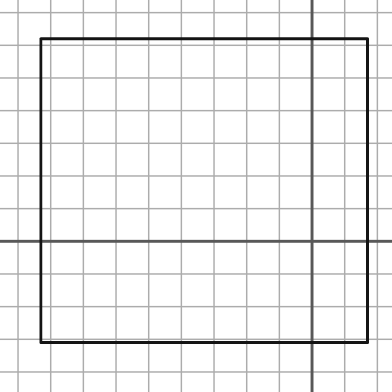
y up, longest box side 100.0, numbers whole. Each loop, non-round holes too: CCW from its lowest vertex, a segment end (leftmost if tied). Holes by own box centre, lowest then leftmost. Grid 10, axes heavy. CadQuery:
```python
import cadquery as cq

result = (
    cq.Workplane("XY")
    .moveTo(-83.0, -31.0)
    .lineTo(17.0, -31.0)
    .lineTo(17.0, 62.0)
    .lineTo(-83.0, 62.0)
    .close()
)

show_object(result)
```